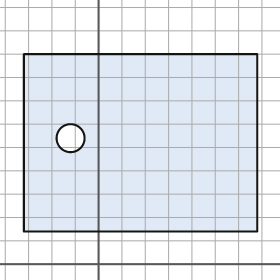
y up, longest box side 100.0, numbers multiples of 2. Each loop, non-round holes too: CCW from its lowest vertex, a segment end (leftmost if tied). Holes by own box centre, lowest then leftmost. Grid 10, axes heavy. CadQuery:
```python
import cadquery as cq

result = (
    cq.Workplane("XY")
    .moveTo(-32.0, 14.0)
    .lineTo(68.0, 14.0)
    .lineTo(68.0, 90.0)
    .lineTo(-32.0, 90.0)
    .close()
    .moveTo(-12.0, 54.0)
    .circle(6.0)
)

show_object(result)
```